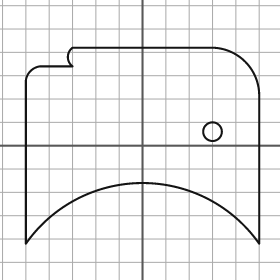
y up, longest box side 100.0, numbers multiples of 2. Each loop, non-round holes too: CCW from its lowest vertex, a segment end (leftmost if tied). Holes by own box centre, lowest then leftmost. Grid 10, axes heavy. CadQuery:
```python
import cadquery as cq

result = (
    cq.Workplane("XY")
    .moveTo(-50.0, -42.0)
    .threePointArc((0.0, -16.0), (50.0, -42.0))
    .lineTo(50.0, 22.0)
    .threePointArc((44.0, 36.0), (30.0, 42.0))
    .lineTo(-30.0, 42.0)
    .threePointArc((-32.0, 38.0), (-30.0, 34.0))
    .lineTo(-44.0, 34.0)
    .threePointArc((-48.0, 32.0), (-50.0, 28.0))
    .close()
    .moveTo(30.0, 6.0)
    .circle(4.0)
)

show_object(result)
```